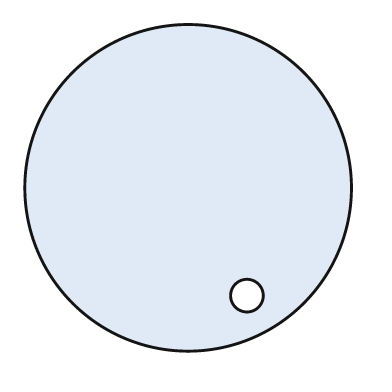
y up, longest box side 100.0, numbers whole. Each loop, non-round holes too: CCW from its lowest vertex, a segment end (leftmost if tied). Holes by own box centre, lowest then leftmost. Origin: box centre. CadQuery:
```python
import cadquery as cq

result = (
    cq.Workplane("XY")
    .moveTo(0.0, 0.0)
    .circle(50.0)
    .moveTo(18.0, -33.0)
    .circle(5.0)
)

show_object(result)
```